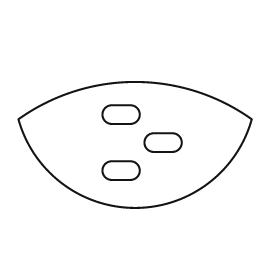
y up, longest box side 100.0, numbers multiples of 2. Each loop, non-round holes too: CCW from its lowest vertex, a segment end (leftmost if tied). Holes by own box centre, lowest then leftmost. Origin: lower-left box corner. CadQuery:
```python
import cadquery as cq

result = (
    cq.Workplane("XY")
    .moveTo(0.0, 38.0)
    .threePointArc((50.0, 0.0), (100.0, 38.0))
    .threePointArc((50.0, 54.0), (0.0, 38.0))
    .close()
    .moveTo(40.0, 12.0)
    .lineTo(48.0, 12.0)
    .threePointArc((52.0, 16.0), (48.0, 20.0))
    .lineTo(40.0, 20.0)
    .threePointArc((36.0, 16.0), (40.0, 12.0))
    .close()
    .moveTo(58.0, 24.0)
    .lineTo(66.0, 24.0)
    .threePointArc((70.0, 28.0), (66.0, 32.0))
    .lineTo(58.0, 32.0)
    .threePointArc((54.0, 28.0), (58.0, 24.0))
    .close()
    .moveTo(40.0, 36.0)
    .lineTo(48.0, 36.0)
    .threePointArc((52.0, 40.0), (48.0, 44.0))
    .lineTo(40.0, 44.0)
    .threePointArc((36.0, 40.0), (40.0, 36.0))
    .close()
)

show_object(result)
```